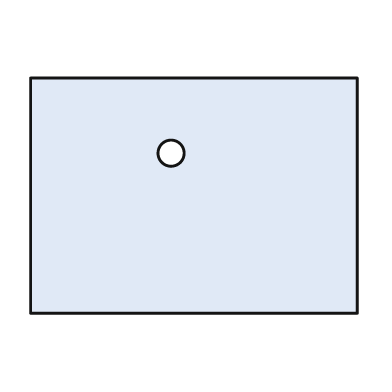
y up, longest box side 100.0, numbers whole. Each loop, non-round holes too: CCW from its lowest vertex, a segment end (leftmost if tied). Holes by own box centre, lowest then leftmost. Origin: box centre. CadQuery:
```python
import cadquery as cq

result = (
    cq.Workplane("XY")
    .moveTo(-50.0, -36.0)
    .lineTo(50.0, -36.0)
    .lineTo(50.0, 36.0)
    .lineTo(-50.0, 36.0)
    .close()
    .moveTo(-7.0, 13.0)
    .circle(4.0)
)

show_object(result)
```